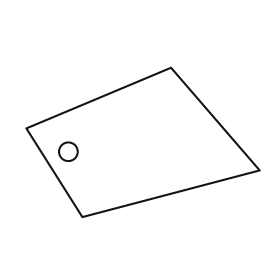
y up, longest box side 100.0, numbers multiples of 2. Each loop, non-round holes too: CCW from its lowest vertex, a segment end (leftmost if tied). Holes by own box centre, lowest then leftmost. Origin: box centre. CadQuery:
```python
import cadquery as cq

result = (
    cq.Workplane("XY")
    .moveTo(-26.0, -32.0)
    .lineTo(50.0, -12.0)
    .lineTo(12.0, 32.0)
    .lineTo(-50.0, 6.0)
    .close()
    .moveTo(-32.0, -4.0)
    .circle(4.0)
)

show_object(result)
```